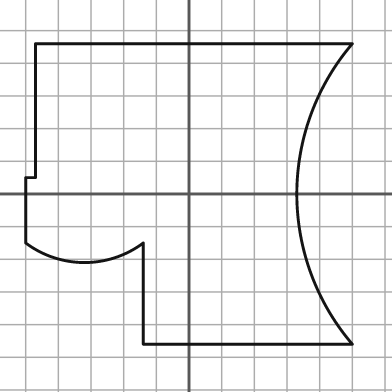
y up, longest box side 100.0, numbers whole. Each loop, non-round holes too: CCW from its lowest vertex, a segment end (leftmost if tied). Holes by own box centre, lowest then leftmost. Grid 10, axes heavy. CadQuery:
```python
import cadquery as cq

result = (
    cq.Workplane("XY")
    .moveTo(-14.0, -46.0)
    .lineTo(50.0, -46.0)
    .threePointArc((33.0, 0.0), (50.0, 46.0))
    .lineTo(-47.0, 46.0)
    .lineTo(-47.0, 5.0)
    .lineTo(-50.0, 5.0)
    .lineTo(-50.0, -15.0)
    .threePointArc((-32.0, -21.0), (-14.0, -15.0))
    .close()
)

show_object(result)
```